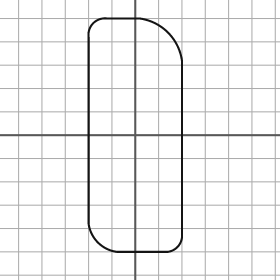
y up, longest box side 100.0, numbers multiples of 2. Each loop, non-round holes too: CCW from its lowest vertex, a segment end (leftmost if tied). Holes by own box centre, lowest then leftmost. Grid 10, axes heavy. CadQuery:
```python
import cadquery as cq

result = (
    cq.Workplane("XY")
    .moveTo(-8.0, -50.0)
    .lineTo(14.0, -50.0)
    .threePointArc((18.0, -48.0), (20.0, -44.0))
    .lineTo(20.0, 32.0)
    .threePointArc((14.0, 44.0), (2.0, 50.0))
    .lineTo(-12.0, 50.0)
    .threePointArc((-18.0, 48.0), (-20.0, 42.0))
    .lineTo(-20.0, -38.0)
    .threePointArc((-16.0, -46.0), (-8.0, -50.0))
    .close()
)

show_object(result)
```